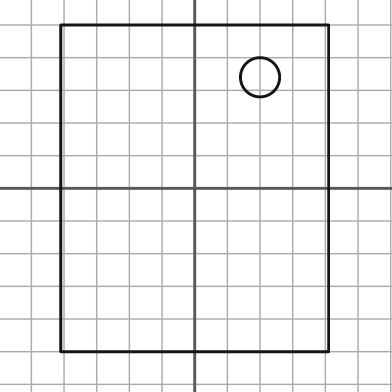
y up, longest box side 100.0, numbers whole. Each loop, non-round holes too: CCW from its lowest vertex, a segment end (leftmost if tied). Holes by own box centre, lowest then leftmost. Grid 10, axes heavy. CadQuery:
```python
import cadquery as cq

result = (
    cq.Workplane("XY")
    .moveTo(-41.0, -50.0)
    .lineTo(41.0, -50.0)
    .lineTo(41.0, 50.0)
    .lineTo(-41.0, 50.0)
    .close()
    .moveTo(20.0, 34.0)
    .circle(6.0)
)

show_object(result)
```